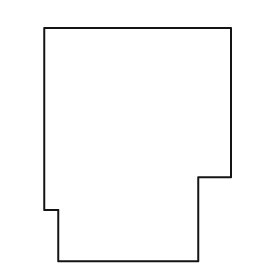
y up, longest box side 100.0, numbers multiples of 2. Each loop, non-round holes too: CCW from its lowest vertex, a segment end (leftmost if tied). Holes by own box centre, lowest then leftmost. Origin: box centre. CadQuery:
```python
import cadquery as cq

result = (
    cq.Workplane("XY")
    .moveTo(-34.0, -50.0)
    .lineTo(26.0, -50.0)
    .lineTo(26.0, -14.0)
    .lineTo(40.0, -14.0)
    .lineTo(40.0, 50.0)
    .lineTo(-40.0, 50.0)
    .lineTo(-40.0, -28.0)
    .lineTo(-34.0, -28.0)
    .close()
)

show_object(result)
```